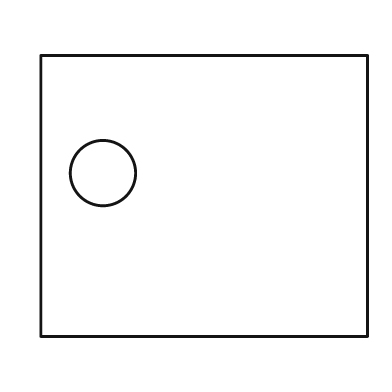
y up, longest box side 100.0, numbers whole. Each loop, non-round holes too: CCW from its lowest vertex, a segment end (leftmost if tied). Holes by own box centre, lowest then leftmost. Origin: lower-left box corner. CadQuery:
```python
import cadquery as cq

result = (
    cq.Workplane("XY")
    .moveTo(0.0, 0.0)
    .lineTo(100.0, 0.0)
    .lineTo(100.0, 86.0)
    .lineTo(0.0, 86.0)
    .close()
    .moveTo(19.0, 50.0)
    .circle(10.0)
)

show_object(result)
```